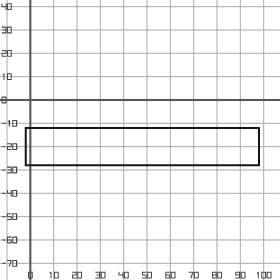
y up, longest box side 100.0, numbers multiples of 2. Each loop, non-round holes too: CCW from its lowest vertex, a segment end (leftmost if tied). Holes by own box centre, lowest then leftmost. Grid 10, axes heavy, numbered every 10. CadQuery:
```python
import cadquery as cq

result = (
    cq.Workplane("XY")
    .moveTo(-2.0, -28.0)
    .lineTo(98.0, -28.0)
    .lineTo(98.0, -12.0)
    .lineTo(-2.0, -12.0)
    .close()
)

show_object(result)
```